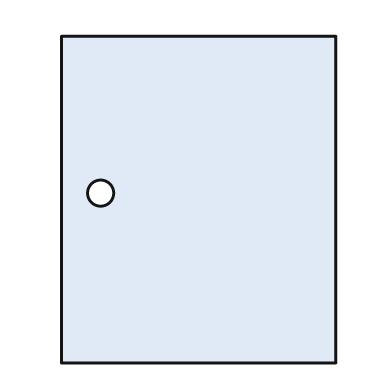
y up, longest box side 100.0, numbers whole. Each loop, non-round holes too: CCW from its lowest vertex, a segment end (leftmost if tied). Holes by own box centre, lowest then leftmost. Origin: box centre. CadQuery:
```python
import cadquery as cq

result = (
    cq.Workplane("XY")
    .moveTo(-42.0, -50.0)
    .lineTo(42.0, -50.0)
    .lineTo(42.0, 50.0)
    .lineTo(-42.0, 50.0)
    .close()
    .moveTo(-30.0, 2.0)
    .circle(4.0)
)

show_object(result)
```